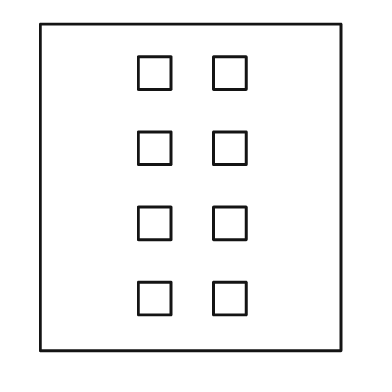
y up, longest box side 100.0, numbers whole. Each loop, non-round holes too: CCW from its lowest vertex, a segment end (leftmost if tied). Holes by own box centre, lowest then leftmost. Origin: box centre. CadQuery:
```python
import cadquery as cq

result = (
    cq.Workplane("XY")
    .moveTo(-46.0, -50.0)
    .lineTo(46.0, -50.0)
    .lineTo(46.0, 50.0)
    .lineTo(-46.0, 50.0)
    .close()
    .moveTo(-16.0, -39.0)
    .lineTo(-6.0, -39.0)
    .lineTo(-6.0, -29.0)
    .lineTo(-16.0, -29.0)
    .close()
    .moveTo(7.0, -39.0)
    .lineTo(17.0, -39.0)
    .lineTo(17.0, -29.0)
    .lineTo(7.0, -29.0)
    .close()
    .moveTo(-16.0, -16.0)
    .lineTo(-6.0, -16.0)
    .lineTo(-6.0, -6.0)
    .lineTo(-16.0, -6.0)
    .close()
    .moveTo(7.0, -16.0)
    .lineTo(17.0, -16.0)
    .lineTo(17.0, -6.0)
    .lineTo(7.0, -6.0)
    .close()
    .moveTo(-16.0, 7.0)
    .lineTo(-6.0, 7.0)
    .lineTo(-6.0, 17.0)
    .lineTo(-16.0, 17.0)
    .close()
    .moveTo(7.0, 7.0)
    .lineTo(17.0, 7.0)
    .lineTo(17.0, 17.0)
    .lineTo(7.0, 17.0)
    .close()
    .moveTo(-16.0, 30.0)
    .lineTo(-6.0, 30.0)
    .lineTo(-6.0, 40.0)
    .lineTo(-16.0, 40.0)
    .close()
    .moveTo(7.0, 30.0)
    .lineTo(17.0, 30.0)
    .lineTo(17.0, 40.0)
    .lineTo(7.0, 40.0)
    .close()
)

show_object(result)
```